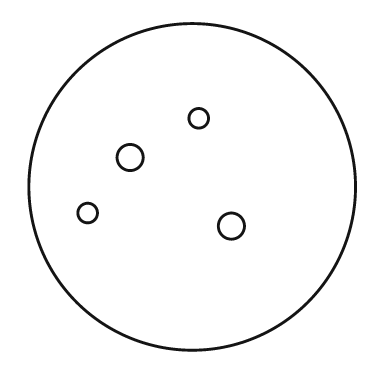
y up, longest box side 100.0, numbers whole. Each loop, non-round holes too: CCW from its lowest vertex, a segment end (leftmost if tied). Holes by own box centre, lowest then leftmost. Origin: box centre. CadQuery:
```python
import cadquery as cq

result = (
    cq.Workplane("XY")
    .moveTo(0.0, 0.0)
    .circle(50.0)
    .moveTo(12.0, -12.0)
    .circle(4.0)
    .moveTo(-32.0, -8.0)
    .circle(3.0)
    .moveTo(-19.0, 9.0)
    .circle(4.0)
    .moveTo(2.0, 21.0)
    .circle(3.0)
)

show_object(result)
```